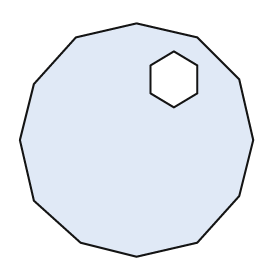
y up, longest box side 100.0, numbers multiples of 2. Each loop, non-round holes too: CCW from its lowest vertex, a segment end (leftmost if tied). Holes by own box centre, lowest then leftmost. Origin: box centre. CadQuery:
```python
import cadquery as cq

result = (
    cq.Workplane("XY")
    .moveTo(0.0, -50.0)
    .lineTo(26.0, -44.0)
    .lineTo(44.0, -24.0)
    .lineTo(50.0, 0.0)
    .lineTo(44.0, 26.0)
    .lineTo(26.0, 44.0)
    .lineTo(0.0, 50.0)
    .lineTo(-26.0, 44.0)
    .lineTo(-44.0, 24.0)
    .lineTo(-50.0, 0.0)
    .lineTo(-44.0, -26.0)
    .lineTo(-24.0, -44.0)
    .close()
    .moveTo(16.0, 14.0)
    .lineTo(26.0, 20.0)
    .lineTo(26.0, 32.0)
    .lineTo(16.0, 38.0)
    .lineTo(6.0, 32.0)
    .lineTo(6.0, 20.0)
    .close()
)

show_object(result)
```